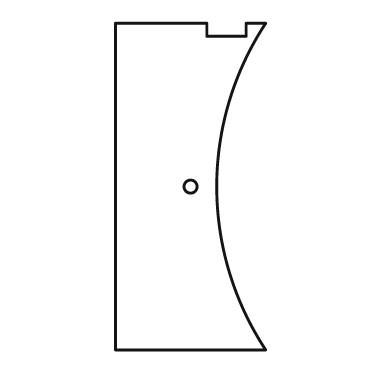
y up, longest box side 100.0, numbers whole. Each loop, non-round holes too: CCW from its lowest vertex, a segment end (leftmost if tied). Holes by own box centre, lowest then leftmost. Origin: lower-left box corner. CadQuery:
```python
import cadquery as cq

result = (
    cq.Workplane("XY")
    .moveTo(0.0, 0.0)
    .lineTo(46.0, 0.0)
    .threePointArc((31.0, 50.0), (46.0, 100.0))
    .lineTo(40.0, 100.0)
    .lineTo(40.0, 96.0)
    .lineTo(28.0, 96.0)
    .lineTo(28.0, 100.0)
    .lineTo(0.0, 100.0)
    .close()
    .moveTo(23.0, 50.0)
    .circle(2.0)
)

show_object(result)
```